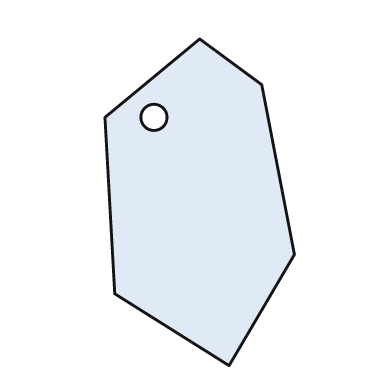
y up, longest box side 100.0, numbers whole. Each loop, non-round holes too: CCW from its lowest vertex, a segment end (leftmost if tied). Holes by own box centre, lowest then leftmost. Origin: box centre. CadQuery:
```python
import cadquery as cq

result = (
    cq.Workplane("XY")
    .moveTo(9.0, -50.0)
    .lineTo(29.0, -16.0)
    .lineTo(19.0, 36.0)
    .lineTo(0.0, 50.0)
    .lineTo(-29.0, 26.0)
    .lineTo(-26.0, -28.0)
    .close()
    .moveTo(-14.0, 26.0)
    .circle(4.0)
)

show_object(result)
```